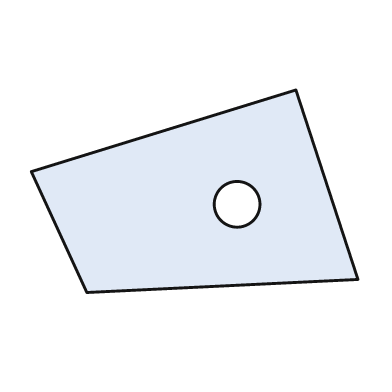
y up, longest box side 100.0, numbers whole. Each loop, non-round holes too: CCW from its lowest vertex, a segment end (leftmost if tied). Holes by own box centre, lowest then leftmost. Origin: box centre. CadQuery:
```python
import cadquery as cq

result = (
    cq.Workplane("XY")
    .moveTo(-33.0, -31.0)
    .lineTo(50.0, -27.0)
    .lineTo(31.0, 31.0)
    .lineTo(-50.0, 6.0)
    .close()
    .moveTo(13.0, -4.0)
    .circle(7.0)
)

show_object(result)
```